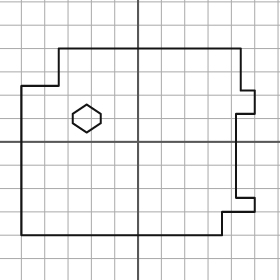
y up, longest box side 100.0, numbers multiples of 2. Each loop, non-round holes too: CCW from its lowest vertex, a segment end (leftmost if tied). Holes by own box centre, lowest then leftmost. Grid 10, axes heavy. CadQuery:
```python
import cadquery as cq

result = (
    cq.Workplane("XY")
    .moveTo(-50.0, -40.0)
    .lineTo(36.0, -40.0)
    .lineTo(36.0, -30.0)
    .lineTo(50.0, -30.0)
    .lineTo(50.0, -24.0)
    .lineTo(42.0, -24.0)
    .lineTo(42.0, 12.0)
    .lineTo(50.0, 12.0)
    .lineTo(50.0, 22.0)
    .lineTo(44.0, 22.0)
    .lineTo(44.0, 40.0)
    .lineTo(-34.0, 40.0)
    .lineTo(-34.0, 24.0)
    .lineTo(-50.0, 24.0)
    .close()
    .moveTo(-22.0, 4.0)
    .lineTo(-16.0, 8.0)
    .lineTo(-16.0, 12.0)
    .lineTo(-22.0, 16.0)
    .lineTo(-28.0, 12.0)
    .lineTo(-28.0, 8.0)
    .close()
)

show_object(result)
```